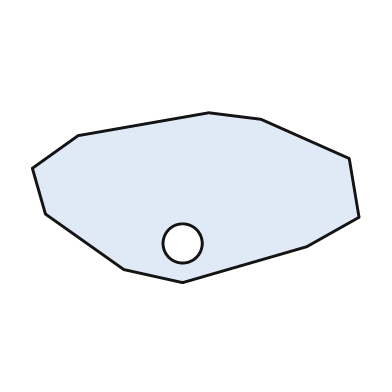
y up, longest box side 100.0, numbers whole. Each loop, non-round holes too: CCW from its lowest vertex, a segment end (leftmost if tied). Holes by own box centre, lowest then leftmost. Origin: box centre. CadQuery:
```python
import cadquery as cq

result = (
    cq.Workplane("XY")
    .moveTo(-4.0, -26.0)
    .lineTo(34.0, -15.0)
    .lineTo(50.0, -6.0)
    .lineTo(47.0, 12.0)
    .lineTo(20.0, 24.0)
    .lineTo(4.0, 26.0)
    .lineTo(-36.0, 19.0)
    .lineTo(-50.0, 9.0)
    .lineTo(-46.0, -5.0)
    .lineTo(-22.0, -22.0)
    .close()
    .moveTo(-4.0, -14.0)
    .circle(6.0)
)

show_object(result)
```